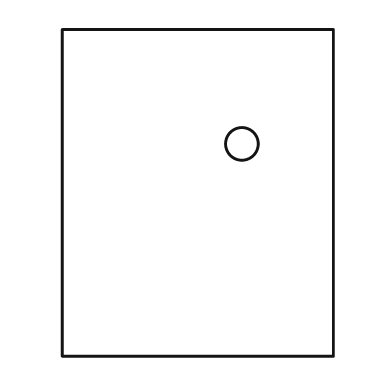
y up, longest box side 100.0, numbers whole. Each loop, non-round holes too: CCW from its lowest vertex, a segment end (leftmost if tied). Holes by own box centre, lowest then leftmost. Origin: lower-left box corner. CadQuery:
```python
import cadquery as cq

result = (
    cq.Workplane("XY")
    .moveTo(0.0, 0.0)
    .lineTo(83.0, 0.0)
    .lineTo(83.0, 100.0)
    .lineTo(0.0, 100.0)
    .close()
    .moveTo(55.0, 65.0)
    .circle(5.0)
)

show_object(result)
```